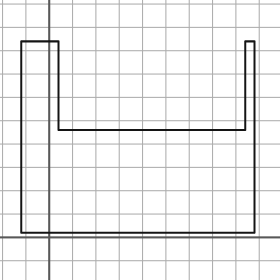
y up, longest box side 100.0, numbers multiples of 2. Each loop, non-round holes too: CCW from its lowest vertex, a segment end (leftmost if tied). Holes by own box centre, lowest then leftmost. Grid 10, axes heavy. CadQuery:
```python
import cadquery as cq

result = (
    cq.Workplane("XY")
    .moveTo(-12.0, 2.0)
    .lineTo(88.0, 2.0)
    .lineTo(88.0, 84.0)
    .lineTo(84.0, 84.0)
    .lineTo(84.0, 46.0)
    .lineTo(4.0, 46.0)
    .lineTo(4.0, 84.0)
    .lineTo(-12.0, 84.0)
    .close()
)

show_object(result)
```